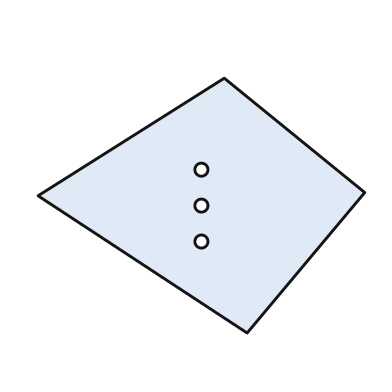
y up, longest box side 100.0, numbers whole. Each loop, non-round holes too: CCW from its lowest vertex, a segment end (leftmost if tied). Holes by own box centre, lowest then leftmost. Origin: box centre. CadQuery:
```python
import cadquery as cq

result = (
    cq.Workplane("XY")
    .moveTo(14.0, -39.0)
    .lineTo(50.0, 4.0)
    .lineTo(7.0, 39.0)
    .lineTo(-50.0, 3.0)
    .close()
    .moveTo(0.0, -11.0)
    .circle(2.0)
    .moveTo(0.0, 0.0)
    .circle(2.0)
    .moveTo(0.0, 11.0)
    .circle(2.0)
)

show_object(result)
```